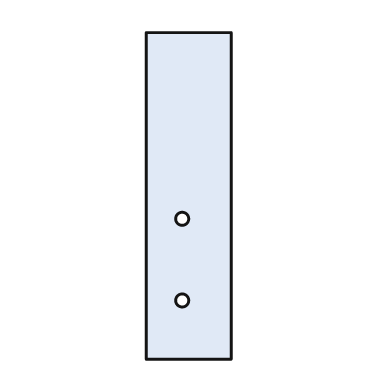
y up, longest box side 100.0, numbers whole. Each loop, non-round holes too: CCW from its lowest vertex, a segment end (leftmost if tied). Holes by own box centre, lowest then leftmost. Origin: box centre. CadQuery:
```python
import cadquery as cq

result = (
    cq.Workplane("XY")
    .moveTo(-13.0, -50.0)
    .lineTo(13.0, -50.0)
    .lineTo(13.0, 50.0)
    .lineTo(-13.0, 50.0)
    .close()
    .moveTo(-2.0, -32.0)
    .circle(2.0)
    .moveTo(-2.0, -7.0)
    .circle(2.0)
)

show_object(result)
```